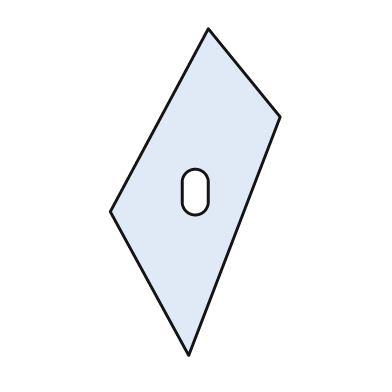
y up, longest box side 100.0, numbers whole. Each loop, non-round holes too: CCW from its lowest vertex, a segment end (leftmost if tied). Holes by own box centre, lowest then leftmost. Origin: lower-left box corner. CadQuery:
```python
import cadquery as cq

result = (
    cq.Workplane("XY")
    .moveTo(24.0, 0.0)
    .lineTo(52.0, 73.0)
    .lineTo(30.0, 100.0)
    .lineTo(0.0, 44.0)
    .close()
    .moveTo(22.0, 47.0)
    .threePointArc((26.0, 43.0), (30.0, 47.0))
    .lineTo(30.0, 53.0)
    .threePointArc((26.0, 57.0), (22.0, 53.0))
    .close()
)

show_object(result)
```